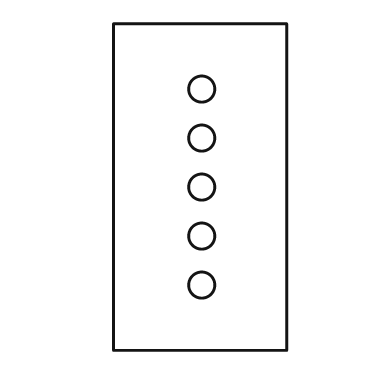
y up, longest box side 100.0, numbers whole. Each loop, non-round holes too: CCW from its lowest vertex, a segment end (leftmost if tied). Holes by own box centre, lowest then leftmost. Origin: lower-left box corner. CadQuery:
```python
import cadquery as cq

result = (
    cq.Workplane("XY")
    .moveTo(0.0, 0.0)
    .lineTo(53.0, 0.0)
    .lineTo(53.0, 100.0)
    .lineTo(0.0, 100.0)
    .close()
    .moveTo(27.0, 20.0)
    .circle(4.0)
    .moveTo(27.0, 35.0)
    .circle(4.0)
    .moveTo(27.0, 50.0)
    .circle(4.0)
    .moveTo(27.0, 65.0)
    .circle(4.0)
    .moveTo(27.0, 80.0)
    .circle(4.0)
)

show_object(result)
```